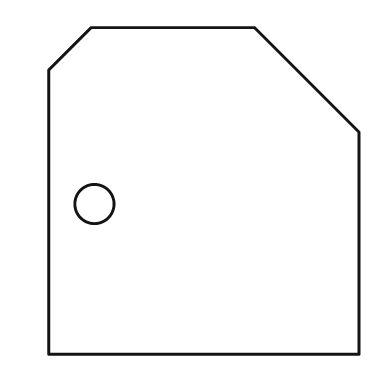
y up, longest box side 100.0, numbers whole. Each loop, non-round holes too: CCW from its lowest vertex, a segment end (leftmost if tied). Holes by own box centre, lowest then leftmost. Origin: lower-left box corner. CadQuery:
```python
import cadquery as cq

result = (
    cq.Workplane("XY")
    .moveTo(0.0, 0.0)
    .lineTo(95.0, 0.0)
    .lineTo(95.0, 68.0)
    .lineTo(63.0, 100.0)
    .lineTo(13.0, 100.0)
    .lineTo(0.0, 87.0)
    .close()
    .moveTo(14.0, 46.0)
    .circle(6.0)
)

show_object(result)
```